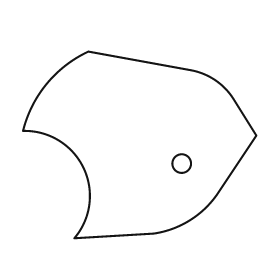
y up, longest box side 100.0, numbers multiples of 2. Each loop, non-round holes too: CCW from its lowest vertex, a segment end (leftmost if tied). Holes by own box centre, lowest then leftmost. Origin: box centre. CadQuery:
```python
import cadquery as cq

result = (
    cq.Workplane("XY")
    .moveTo(-28.0, -40.0)
    .lineTo(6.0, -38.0)
    .threePointArc((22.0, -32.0), (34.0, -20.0))
    .lineTo(50.0, 4.0)
    .lineTo(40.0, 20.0)
    .threePointArc((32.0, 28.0), (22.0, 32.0))
    .lineTo(-22.0, 40.0)
    .threePointArc((-40.0, 26.0), (-50.0, 6.0))
    .threePointArc((-24.0, -10.0), (-28.0, -40.0))
    .close()
    .moveTo(18.0, -8.0)
    .circle(4.0)
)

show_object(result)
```